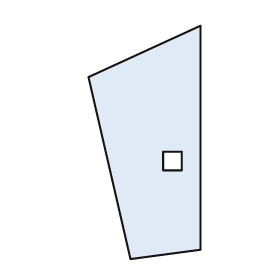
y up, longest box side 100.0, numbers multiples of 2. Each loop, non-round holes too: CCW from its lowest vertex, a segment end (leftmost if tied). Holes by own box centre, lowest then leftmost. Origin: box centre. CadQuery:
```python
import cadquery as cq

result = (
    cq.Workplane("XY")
    .moveTo(-6.0, -50.0)
    .lineTo(24.0, -46.0)
    .lineTo(24.0, 50.0)
    .lineTo(-24.0, 28.0)
    .close()
    .moveTo(8.0, -12.0)
    .lineTo(16.0, -12.0)
    .lineTo(16.0, -4.0)
    .lineTo(8.0, -4.0)
    .close()
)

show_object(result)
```